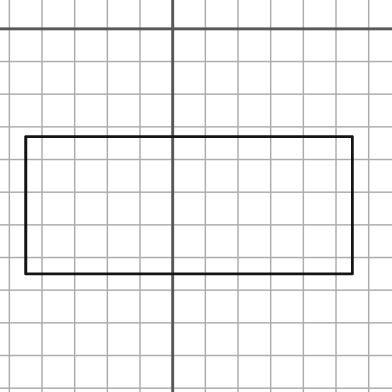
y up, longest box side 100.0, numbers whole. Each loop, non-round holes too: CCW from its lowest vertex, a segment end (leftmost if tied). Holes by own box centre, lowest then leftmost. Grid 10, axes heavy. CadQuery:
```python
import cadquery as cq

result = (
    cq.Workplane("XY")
    .moveTo(-45.0, -75.0)
    .lineTo(55.0, -75.0)
    .lineTo(55.0, -33.0)
    .lineTo(-45.0, -33.0)
    .close()
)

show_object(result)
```